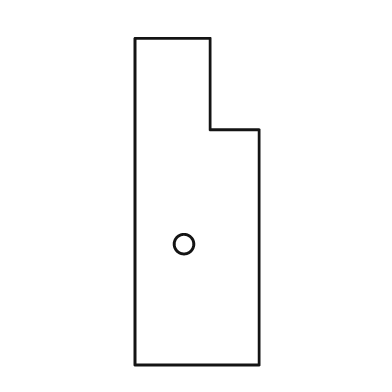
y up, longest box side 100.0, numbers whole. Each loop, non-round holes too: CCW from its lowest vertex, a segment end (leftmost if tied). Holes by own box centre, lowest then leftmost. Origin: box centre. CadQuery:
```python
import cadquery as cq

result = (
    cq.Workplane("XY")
    .moveTo(-19.0, -50.0)
    .lineTo(19.0, -50.0)
    .lineTo(19.0, 22.0)
    .lineTo(4.0, 22.0)
    .lineTo(4.0, 50.0)
    .lineTo(-19.0, 50.0)
    .close()
    .moveTo(-4.0, -13.0)
    .circle(3.0)
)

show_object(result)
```